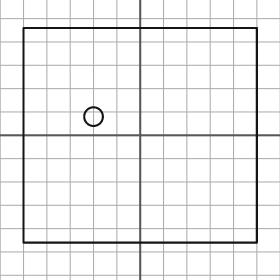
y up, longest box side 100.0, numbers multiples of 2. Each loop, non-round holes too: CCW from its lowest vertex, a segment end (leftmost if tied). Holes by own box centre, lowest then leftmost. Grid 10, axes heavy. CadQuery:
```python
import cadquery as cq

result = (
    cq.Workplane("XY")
    .moveTo(-50.0, -46.0)
    .lineTo(50.0, -46.0)
    .lineTo(50.0, 46.0)
    .lineTo(-50.0, 46.0)
    .close()
    .moveTo(-20.0, 8.0)
    .circle(4.0)
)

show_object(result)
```